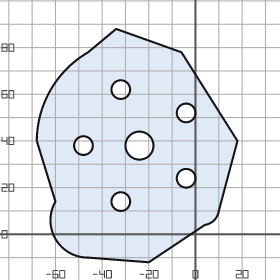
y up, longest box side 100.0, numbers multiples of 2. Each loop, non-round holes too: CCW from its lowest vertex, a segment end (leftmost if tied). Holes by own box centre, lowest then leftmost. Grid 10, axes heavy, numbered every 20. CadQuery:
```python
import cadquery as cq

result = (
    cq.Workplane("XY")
    .moveTo(-20.0, -12.0)
    .lineTo(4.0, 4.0)
    .threePointArc((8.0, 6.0), (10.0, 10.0))
    .lineTo(18.0, 40.0)
    .lineTo(-6.0, 78.0)
    .lineTo(-34.0, 88.0)
    .lineTo(-46.0, 78.0)
    .threePointArc((-62.0, 62.0), (-68.0, 40.0))
    .lineTo(-60.0, 14.0)
    .threePointArc((-60.0, -2.0), (-46.0, -10.0))
    .close()
    .moveTo(-32.0, 14.0)
    .circle(4.0)
    .moveTo(-4.0, 24.0)
    .circle(4.0)
    .moveTo(-48.0, 38.0)
    .circle(4.0)
    .moveTo(-24.0, 38.0)
    .circle(6.0)
    .moveTo(-4.0, 52.0)
    .circle(4.0)
    .moveTo(-32.0, 62.0)
    .circle(4.0)
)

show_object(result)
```